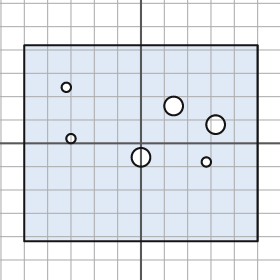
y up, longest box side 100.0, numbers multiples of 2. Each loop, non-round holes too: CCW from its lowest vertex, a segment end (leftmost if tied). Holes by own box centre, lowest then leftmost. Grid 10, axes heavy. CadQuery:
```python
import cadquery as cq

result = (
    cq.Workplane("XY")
    .moveTo(-50.0, -42.0)
    .lineTo(50.0, -42.0)
    .lineTo(50.0, 42.0)
    .lineTo(-50.0, 42.0)
    .close()
    .moveTo(28.0, -8.0)
    .circle(2.0)
    .moveTo(0.0, -6.0)
    .circle(4.0)
    .moveTo(-30.0, 2.0)
    .circle(2.0)
    .moveTo(32.0, 8.0)
    .circle(4.0)
    .moveTo(14.0, 16.0)
    .circle(4.0)
    .moveTo(-32.0, 24.0)
    .circle(2.0)
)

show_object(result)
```